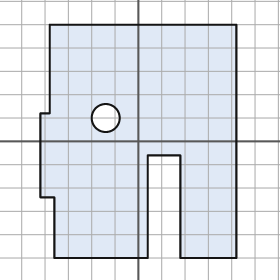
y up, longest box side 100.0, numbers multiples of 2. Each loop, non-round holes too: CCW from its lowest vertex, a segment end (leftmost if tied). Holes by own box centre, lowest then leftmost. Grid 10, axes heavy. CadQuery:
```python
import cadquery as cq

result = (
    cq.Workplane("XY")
    .moveTo(-36.0, -50.0)
    .lineTo(4.0, -50.0)
    .lineTo(4.0, -6.0)
    .lineTo(18.0, -6.0)
    .lineTo(18.0, -50.0)
    .lineTo(42.0, -50.0)
    .lineTo(42.0, 50.0)
    .lineTo(-38.0, 50.0)
    .lineTo(-38.0, 12.0)
    .lineTo(-42.0, 12.0)
    .lineTo(-42.0, -24.0)
    .lineTo(-36.0, -24.0)
    .close()
    .moveTo(-14.0, 10.0)
    .circle(6.0)
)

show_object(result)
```